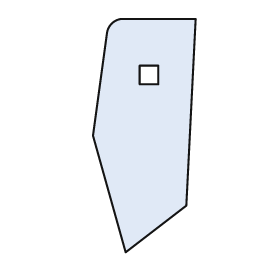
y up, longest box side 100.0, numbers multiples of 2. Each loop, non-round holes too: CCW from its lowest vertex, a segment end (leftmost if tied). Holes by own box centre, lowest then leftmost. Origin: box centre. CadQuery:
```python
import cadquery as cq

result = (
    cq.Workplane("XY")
    .moveTo(-8.0, -50.0)
    .lineTo(18.0, -30.0)
    .lineTo(22.0, 50.0)
    .lineTo(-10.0, 50.0)
    .threePointArc((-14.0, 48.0), (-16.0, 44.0))
    .lineTo(-22.0, 0.0)
    .close()
    .moveTo(-2.0, 22.0)
    .lineTo(6.0, 22.0)
    .lineTo(6.0, 30.0)
    .lineTo(-2.0, 30.0)
    .close()
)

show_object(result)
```